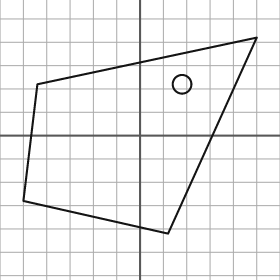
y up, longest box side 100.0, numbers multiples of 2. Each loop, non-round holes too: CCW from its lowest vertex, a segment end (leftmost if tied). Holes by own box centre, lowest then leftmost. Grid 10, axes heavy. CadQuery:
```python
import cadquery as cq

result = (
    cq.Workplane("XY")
    .moveTo(12.0, -42.0)
    .lineTo(50.0, 42.0)
    .lineTo(-44.0, 22.0)
    .lineTo(-50.0, -28.0)
    .close()
    .moveTo(18.0, 22.0)
    .circle(4.0)
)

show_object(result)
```